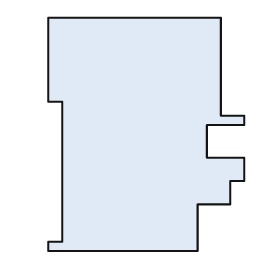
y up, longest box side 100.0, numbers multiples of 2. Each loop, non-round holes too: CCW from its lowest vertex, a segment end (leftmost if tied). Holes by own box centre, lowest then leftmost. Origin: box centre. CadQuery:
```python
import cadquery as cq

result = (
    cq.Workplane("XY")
    .moveTo(-42.0, -50.0)
    .lineTo(22.0, -50.0)
    .lineTo(22.0, -30.0)
    .lineTo(36.0, -30.0)
    .lineTo(36.0, -20.0)
    .lineTo(42.0, -20.0)
    .lineTo(42.0, -10.0)
    .lineTo(26.0, -10.0)
    .lineTo(26.0, 4.0)
    .lineTo(42.0, 4.0)
    .lineTo(42.0, 8.0)
    .lineTo(32.0, 8.0)
    .lineTo(32.0, 50.0)
    .lineTo(-42.0, 50.0)
    .lineTo(-42.0, 14.0)
    .lineTo(-36.0, 14.0)
    .lineTo(-36.0, -46.0)
    .lineTo(-42.0, -46.0)
    .close()
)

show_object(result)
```